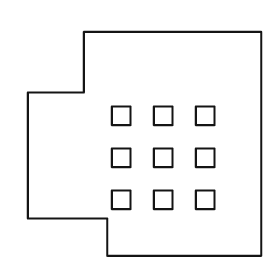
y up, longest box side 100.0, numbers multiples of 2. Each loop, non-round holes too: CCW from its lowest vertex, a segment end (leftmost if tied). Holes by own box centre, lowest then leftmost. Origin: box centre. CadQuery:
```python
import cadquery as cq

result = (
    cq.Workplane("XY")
    .moveTo(-16.0, -48.0)
    .lineTo(50.0, -48.0)
    .lineTo(50.0, 48.0)
    .lineTo(-26.0, 48.0)
    .lineTo(-26.0, 22.0)
    .lineTo(-50.0, 22.0)
    .lineTo(-50.0, -32.0)
    .lineTo(-16.0, -32.0)
    .close()
    .moveTo(-14.0, -28.0)
    .lineTo(-6.0, -28.0)
    .lineTo(-6.0, -20.0)
    .lineTo(-14.0, -20.0)
    .close()
    .moveTo(4.0, -28.0)
    .lineTo(12.0, -28.0)
    .lineTo(12.0, -20.0)
    .lineTo(4.0, -20.0)
    .close()
    .moveTo(22.0, -28.0)
    .lineTo(30.0, -28.0)
    .lineTo(30.0, -20.0)
    .lineTo(22.0, -20.0)
    .close()
    .moveTo(-14.0, -10.0)
    .lineTo(-6.0, -10.0)
    .lineTo(-6.0, -2.0)
    .lineTo(-14.0, -2.0)
    .close()
    .moveTo(4.0, -10.0)
    .lineTo(12.0, -10.0)
    .lineTo(12.0, -2.0)
    .lineTo(4.0, -2.0)
    .close()
    .moveTo(22.0, -10.0)
    .lineTo(30.0, -10.0)
    .lineTo(30.0, -2.0)
    .lineTo(22.0, -2.0)
    .close()
    .moveTo(-14.0, 8.0)
    .lineTo(-6.0, 8.0)
    .lineTo(-6.0, 16.0)
    .lineTo(-14.0, 16.0)
    .close()
    .moveTo(4.0, 8.0)
    .lineTo(12.0, 8.0)
    .lineTo(12.0, 16.0)
    .lineTo(4.0, 16.0)
    .close()
    .moveTo(22.0, 8.0)
    .lineTo(30.0, 8.0)
    .lineTo(30.0, 16.0)
    .lineTo(22.0, 16.0)
    .close()
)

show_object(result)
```